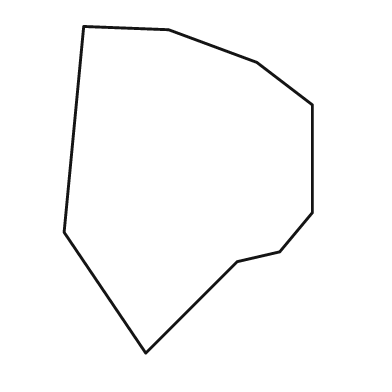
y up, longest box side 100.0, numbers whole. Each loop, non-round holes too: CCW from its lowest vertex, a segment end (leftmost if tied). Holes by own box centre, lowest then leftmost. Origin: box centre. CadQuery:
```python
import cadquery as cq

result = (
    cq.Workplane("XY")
    .moveTo(-13.0, -50.0)
    .lineTo(15.0, -22.0)
    .lineTo(28.0, -19.0)
    .lineTo(38.0, -7.0)
    .lineTo(38.0, 26.0)
    .lineTo(21.0, 39.0)
    .lineTo(-6.0, 49.0)
    .lineTo(-32.0, 50.0)
    .lineTo(-38.0, -13.0)
    .close()
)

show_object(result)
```